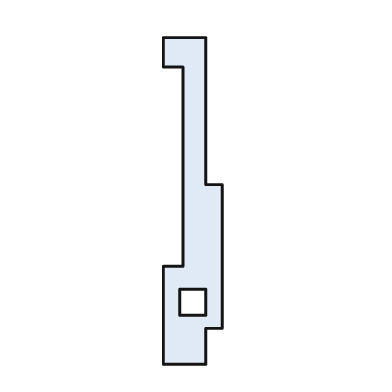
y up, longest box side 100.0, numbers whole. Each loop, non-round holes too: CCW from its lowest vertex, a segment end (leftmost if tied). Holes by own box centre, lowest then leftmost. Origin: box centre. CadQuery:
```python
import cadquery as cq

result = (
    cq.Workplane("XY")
    .moveTo(-9.0, -50.0)
    .lineTo(4.0, -50.0)
    .lineTo(4.0, -39.0)
    .lineTo(9.0, -39.0)
    .lineTo(9.0, 5.0)
    .lineTo(4.0, 5.0)
    .lineTo(4.0, 50.0)
    .lineTo(-9.0, 50.0)
    .lineTo(-9.0, 41.0)
    .lineTo(-3.0, 41.0)
    .lineTo(-3.0, -20.0)
    .lineTo(-9.0, -20.0)
    .close()
    .moveTo(-4.0, -35.0)
    .lineTo(4.0, -35.0)
    .lineTo(4.0, -27.0)
    .lineTo(-4.0, -27.0)
    .close()
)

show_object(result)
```